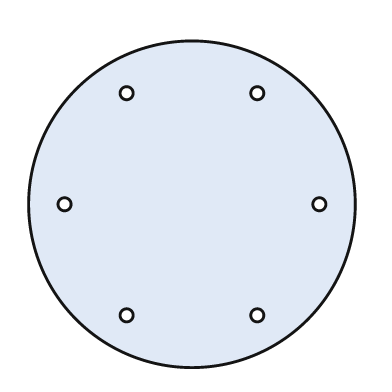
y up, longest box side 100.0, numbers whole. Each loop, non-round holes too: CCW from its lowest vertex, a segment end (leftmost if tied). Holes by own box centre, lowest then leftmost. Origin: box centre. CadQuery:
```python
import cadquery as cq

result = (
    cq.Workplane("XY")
    .moveTo(0.0, 0.0)
    .circle(50.0)
    .moveTo(-20.0, -34.0)
    .circle(2.0)
    .moveTo(20.0, -34.0)
    .circle(2.0)
    .moveTo(-39.0, 0.0)
    .circle(2.0)
    .moveTo(39.0, 0.0)
    .circle(2.0)
    .moveTo(-20.0, 34.0)
    .circle(2.0)
    .moveTo(20.0, 34.0)
    .circle(2.0)
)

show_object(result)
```